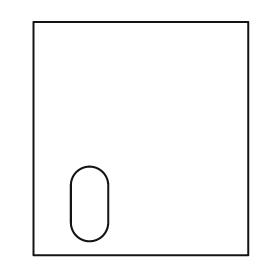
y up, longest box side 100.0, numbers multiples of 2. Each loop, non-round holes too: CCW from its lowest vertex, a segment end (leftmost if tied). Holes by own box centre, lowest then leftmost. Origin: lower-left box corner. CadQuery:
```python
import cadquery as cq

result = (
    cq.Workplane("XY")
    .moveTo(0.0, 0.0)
    .lineTo(92.0, 0.0)
    .lineTo(92.0, 100.0)
    .lineTo(0.0, 100.0)
    .close()
    .moveTo(16.0, 14.0)
    .threePointArc((24.0, 6.0), (32.0, 14.0))
    .lineTo(32.0, 30.0)
    .threePointArc((24.0, 38.0), (16.0, 30.0))
    .close()
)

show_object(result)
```